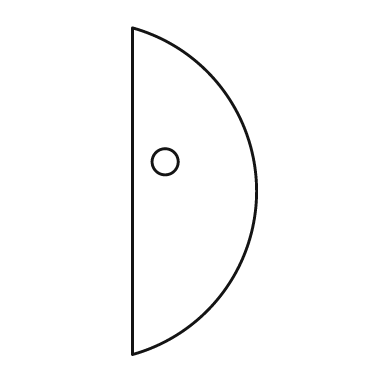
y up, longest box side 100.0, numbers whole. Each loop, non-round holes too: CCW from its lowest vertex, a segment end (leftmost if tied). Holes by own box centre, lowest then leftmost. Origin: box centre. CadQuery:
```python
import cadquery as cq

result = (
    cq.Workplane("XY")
    .moveTo(-19.0, -50.0)
    .threePointArc((19.0, 0.0), (-19.0, 50.0))
    .close()
    .moveTo(-9.0, 9.0)
    .circle(4.0)
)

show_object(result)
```